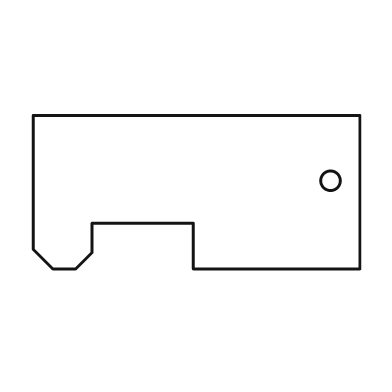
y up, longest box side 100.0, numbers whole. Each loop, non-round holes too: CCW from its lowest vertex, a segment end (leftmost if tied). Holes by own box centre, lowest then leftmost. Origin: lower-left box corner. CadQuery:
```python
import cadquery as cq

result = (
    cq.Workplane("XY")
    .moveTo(6.0, 0.0)
    .lineTo(13.0, 0.0)
    .lineTo(18.0, 5.0)
    .lineTo(18.0, 14.0)
    .lineTo(49.0, 14.0)
    .lineTo(49.0, 0.0)
    .lineTo(100.0, 0.0)
    .lineTo(100.0, 47.0)
    .lineTo(0.0, 47.0)
    .lineTo(0.0, 6.0)
    .close()
    .moveTo(91.0, 27.0)
    .circle(3.0)
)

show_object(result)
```